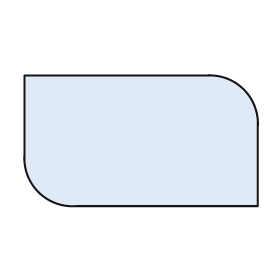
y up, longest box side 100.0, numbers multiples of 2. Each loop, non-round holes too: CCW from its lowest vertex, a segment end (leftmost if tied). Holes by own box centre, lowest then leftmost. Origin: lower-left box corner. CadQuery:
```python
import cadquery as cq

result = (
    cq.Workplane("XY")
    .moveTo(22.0, 0.0)
    .lineTo(100.0, 0.0)
    .lineTo(100.0, 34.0)
    .threePointArc((94.0, 50.0), (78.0, 56.0))
    .lineTo(0.0, 56.0)
    .lineTo(0.0, 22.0)
    .threePointArc((6.0, 6.0), (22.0, 0.0))
    .close()
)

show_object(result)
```